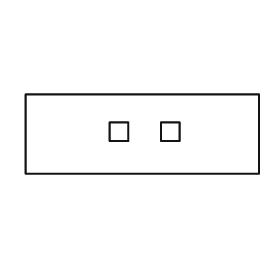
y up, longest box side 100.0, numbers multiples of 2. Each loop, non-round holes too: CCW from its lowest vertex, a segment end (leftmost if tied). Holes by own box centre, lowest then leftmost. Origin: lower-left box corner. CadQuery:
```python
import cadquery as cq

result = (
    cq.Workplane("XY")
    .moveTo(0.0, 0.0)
    .lineTo(100.0, 0.0)
    .lineTo(100.0, 34.0)
    .lineTo(0.0, 34.0)
    .close()
    .moveTo(36.0, 14.0)
    .lineTo(44.0, 14.0)
    .lineTo(44.0, 22.0)
    .lineTo(36.0, 22.0)
    .close()
    .moveTo(58.0, 14.0)
    .lineTo(66.0, 14.0)
    .lineTo(66.0, 22.0)
    .lineTo(58.0, 22.0)
    .close()
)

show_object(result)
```